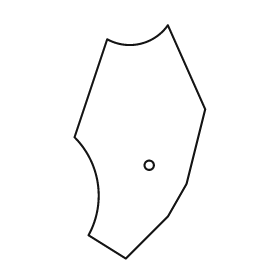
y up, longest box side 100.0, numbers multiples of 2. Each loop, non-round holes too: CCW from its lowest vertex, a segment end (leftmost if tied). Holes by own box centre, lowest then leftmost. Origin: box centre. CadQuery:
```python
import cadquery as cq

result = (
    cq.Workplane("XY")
    .moveTo(-6.0, -50.0)
    .lineTo(12.0, -32.0)
    .lineTo(20.0, -18.0)
    .lineTo(28.0, 14.0)
    .lineTo(12.0, 50.0)
    .threePointArc((0.0, 42.0), (-14.0, 44.0))
    .lineTo(-28.0, 2.0)
    .threePointArc((-18.0, -18.0), (-22.0, -40.0))
    .close()
    .moveTo(4.0, -10.0)
    .circle(2.0)
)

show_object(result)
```